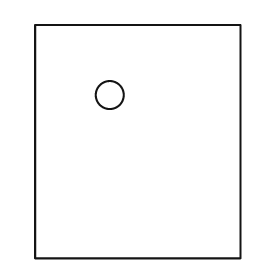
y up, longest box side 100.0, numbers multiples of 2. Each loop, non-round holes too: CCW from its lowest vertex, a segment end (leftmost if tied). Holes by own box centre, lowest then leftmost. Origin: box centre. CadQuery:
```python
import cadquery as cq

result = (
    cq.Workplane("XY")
    .moveTo(-44.0, -50.0)
    .lineTo(44.0, -50.0)
    .lineTo(44.0, 50.0)
    .lineTo(-44.0, 50.0)
    .close()
    .moveTo(-12.0, 20.0)
    .circle(6.0)
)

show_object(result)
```